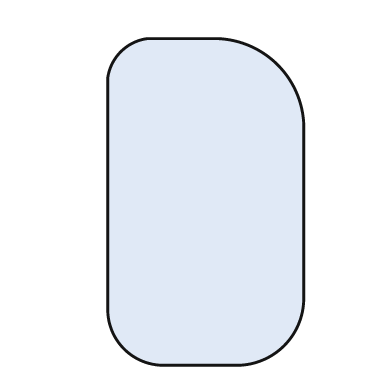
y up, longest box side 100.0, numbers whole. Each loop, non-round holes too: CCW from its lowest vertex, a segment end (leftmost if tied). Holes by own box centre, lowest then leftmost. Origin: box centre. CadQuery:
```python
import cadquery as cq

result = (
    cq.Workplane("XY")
    .moveTo(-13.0, -50.0)
    .lineTo(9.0, -50.0)
    .threePointArc((24.0, -44.0), (30.0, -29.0))
    .lineTo(30.0, 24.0)
    .threePointArc((22.0, 42.0), (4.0, 50.0))
    .lineTo(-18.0, 50.0)
    .threePointArc((-26.0, 46.0), (-30.0, 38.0))
    .lineTo(-30.0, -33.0)
    .threePointArc((-25.0, -45.0), (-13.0, -50.0))
    .close()
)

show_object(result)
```